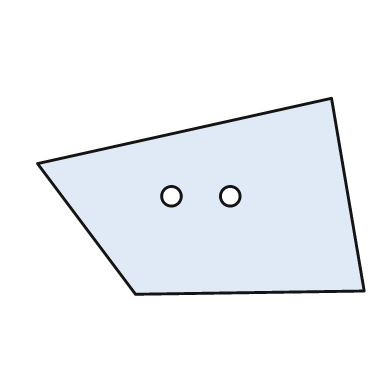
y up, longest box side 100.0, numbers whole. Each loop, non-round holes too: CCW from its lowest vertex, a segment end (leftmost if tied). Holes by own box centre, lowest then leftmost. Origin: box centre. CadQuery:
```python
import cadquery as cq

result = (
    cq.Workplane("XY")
    .moveTo(-20.0, -30.0)
    .lineTo(50.0, -29.0)
    .lineTo(40.0, 30.0)
    .lineTo(-50.0, 10.0)
    .close()
    .moveTo(-9.0, 0.0)
    .circle(3.0)
    .moveTo(9.0, 0.0)
    .circle(3.0)
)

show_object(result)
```